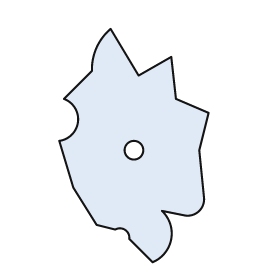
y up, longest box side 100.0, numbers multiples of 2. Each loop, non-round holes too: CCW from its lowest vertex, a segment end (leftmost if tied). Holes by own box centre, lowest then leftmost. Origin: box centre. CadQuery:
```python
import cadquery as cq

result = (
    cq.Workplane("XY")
    .moveTo(8.0, -50.0)
    .threePointArc((16.0, -40.0), (12.0, -28.0))
    .lineTo(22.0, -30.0)
    .threePointArc((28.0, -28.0), (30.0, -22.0))
    .lineTo(28.0, -2.0)
    .lineTo(32.0, 14.0)
    .lineTo(18.0, 20.0)
    .lineTo(16.0, 38.0)
    .lineTo(2.0, 30.0)
    .lineTo(-10.0, 50.0)
    .threePointArc((-16.0, 42.0), (-18.0, 32.0))
    .lineTo(-30.0, 20.0)
    .threePointArc((-24.0, 10.0), (-32.0, 2.0))
    .lineTo(-26.0, -18.0)
    .lineTo(-16.0, -34.0)
    .lineTo(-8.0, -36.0)
    .threePointArc((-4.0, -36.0), (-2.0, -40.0))
    .close()
    .moveTo(0.0, -2.0)
    .circle(4.0)
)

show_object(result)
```